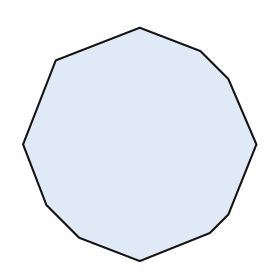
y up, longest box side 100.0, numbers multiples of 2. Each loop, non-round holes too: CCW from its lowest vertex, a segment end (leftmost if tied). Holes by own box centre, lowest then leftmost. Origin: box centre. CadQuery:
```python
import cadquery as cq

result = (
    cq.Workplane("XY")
    .moveTo(0.0, -50.0)
    .lineTo(30.0, -38.0)
    .lineTo(38.0, -30.0)
    .lineTo(50.0, 0.0)
    .lineTo(38.0, 28.0)
    .lineTo(26.0, 40.0)
    .lineTo(0.0, 50.0)
    .lineTo(-36.0, 36.0)
    .lineTo(-50.0, 0.0)
    .lineTo(-40.0, -26.0)
    .lineTo(-26.0, -40.0)
    .close()
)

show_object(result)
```